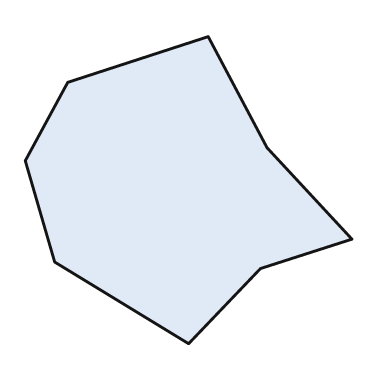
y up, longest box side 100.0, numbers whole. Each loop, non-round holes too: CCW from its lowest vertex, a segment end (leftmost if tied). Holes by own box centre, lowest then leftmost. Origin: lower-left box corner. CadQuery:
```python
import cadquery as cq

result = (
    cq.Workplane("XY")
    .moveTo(50.0, 0.0)
    .lineTo(72.0, 23.0)
    .lineTo(100.0, 32.0)
    .lineTo(74.0, 60.0)
    .lineTo(56.0, 94.0)
    .lineTo(13.0, 80.0)
    .lineTo(0.0, 56.0)
    .lineTo(9.0, 25.0)
    .close()
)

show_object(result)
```